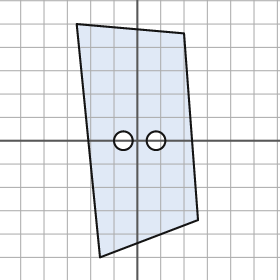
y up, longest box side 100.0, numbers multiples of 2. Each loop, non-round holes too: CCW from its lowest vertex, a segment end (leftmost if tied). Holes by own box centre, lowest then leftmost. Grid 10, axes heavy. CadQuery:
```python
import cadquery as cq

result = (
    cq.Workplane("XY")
    .moveTo(-16.0, -50.0)
    .lineTo(26.0, -34.0)
    .lineTo(20.0, 46.0)
    .lineTo(-26.0, 50.0)
    .close()
    .moveTo(-6.0, 0.0)
    .circle(4.0)
    .moveTo(8.0, 0.0)
    .circle(4.0)
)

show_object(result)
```